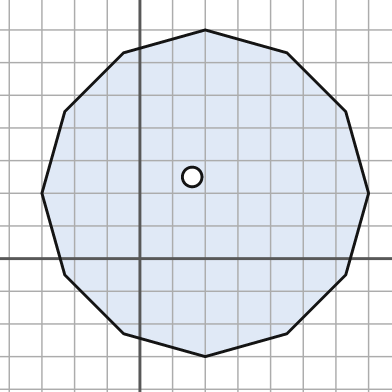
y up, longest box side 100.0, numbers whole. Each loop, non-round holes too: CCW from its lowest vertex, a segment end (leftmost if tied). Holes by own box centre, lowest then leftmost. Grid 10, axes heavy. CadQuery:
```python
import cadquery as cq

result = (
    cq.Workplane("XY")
    .moveTo(20.0, -30.0)
    .lineTo(45.0, -23.0)
    .lineTo(63.0, -5.0)
    .lineTo(70.0, 20.0)
    .lineTo(63.0, 45.0)
    .lineTo(45.0, 63.0)
    .lineTo(20.0, 70.0)
    .lineTo(-5.0, 63.0)
    .lineTo(-23.0, 45.0)
    .lineTo(-30.0, 20.0)
    .lineTo(-23.0, -5.0)
    .lineTo(-5.0, -23.0)
    .close()
    .moveTo(16.0, 25.0)
    .circle(3.0)
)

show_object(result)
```